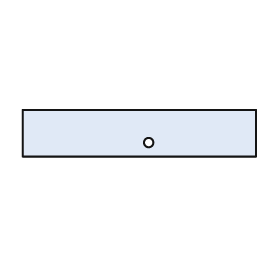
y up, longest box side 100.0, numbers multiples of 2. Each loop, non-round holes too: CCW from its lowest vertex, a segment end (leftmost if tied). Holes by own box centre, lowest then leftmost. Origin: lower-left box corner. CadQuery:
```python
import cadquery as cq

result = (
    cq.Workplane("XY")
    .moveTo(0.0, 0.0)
    .lineTo(100.0, 0.0)
    .lineTo(100.0, 20.0)
    .lineTo(0.0, 20.0)
    .close()
    .moveTo(54.0, 6.0)
    .circle(2.0)
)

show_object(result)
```